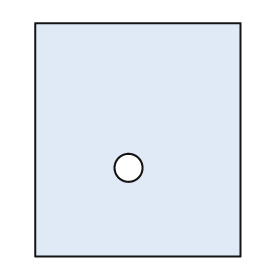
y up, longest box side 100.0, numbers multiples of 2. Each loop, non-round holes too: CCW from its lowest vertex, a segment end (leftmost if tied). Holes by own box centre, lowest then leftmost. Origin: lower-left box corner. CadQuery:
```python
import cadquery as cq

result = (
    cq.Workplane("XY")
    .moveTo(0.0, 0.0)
    .lineTo(88.0, 0.0)
    .lineTo(88.0, 100.0)
    .lineTo(0.0, 100.0)
    .close()
    .moveTo(40.0, 38.0)
    .circle(6.0)
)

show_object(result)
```